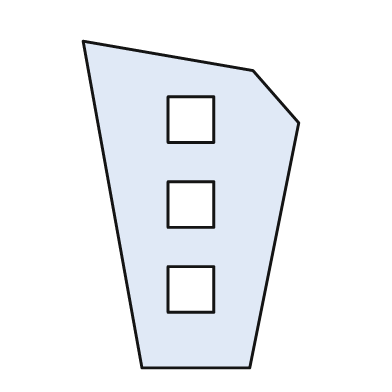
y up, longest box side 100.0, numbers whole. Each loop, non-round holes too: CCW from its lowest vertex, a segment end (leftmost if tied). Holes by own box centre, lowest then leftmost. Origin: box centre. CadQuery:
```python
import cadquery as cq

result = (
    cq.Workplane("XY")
    .moveTo(-15.0, -50.0)
    .lineTo(18.0, -50.0)
    .lineTo(33.0, 25.0)
    .lineTo(19.0, 41.0)
    .lineTo(-33.0, 50.0)
    .close()
    .moveTo(-7.0, -33.0)
    .lineTo(7.0, -33.0)
    .lineTo(7.0, -19.0)
    .lineTo(-7.0, -19.0)
    .close()
    .moveTo(-7.0, -7.0)
    .lineTo(7.0, -7.0)
    .lineTo(7.0, 7.0)
    .lineTo(-7.0, 7.0)
    .close()
    .moveTo(-7.0, 19.0)
    .lineTo(7.0, 19.0)
    .lineTo(7.0, 33.0)
    .lineTo(-7.0, 33.0)
    .close()
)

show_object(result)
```